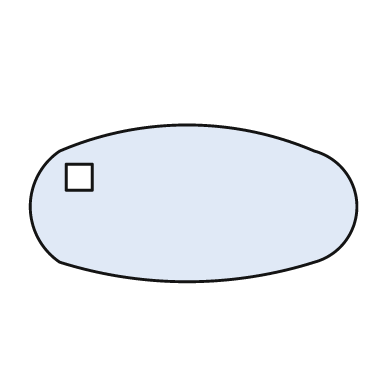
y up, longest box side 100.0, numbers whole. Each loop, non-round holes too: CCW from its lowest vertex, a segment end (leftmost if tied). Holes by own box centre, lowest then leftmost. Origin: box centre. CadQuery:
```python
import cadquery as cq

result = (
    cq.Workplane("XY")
    .moveTo(-41.0, -18.0)
    .threePointArc((-2.0, -24.0), (37.0, -18.0))
    .threePointArc((50.0, -1.0), (37.0, 16.0))
    .threePointArc((-2.0, 24.0), (-41.0, 16.0))
    .threePointArc((-50.0, -1.0), (-41.0, -18.0))
    .close()
    .moveTo(-39.0, 4.0)
    .lineTo(-31.0, 4.0)
    .lineTo(-31.0, 12.0)
    .lineTo(-39.0, 12.0)
    .close()
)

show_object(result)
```